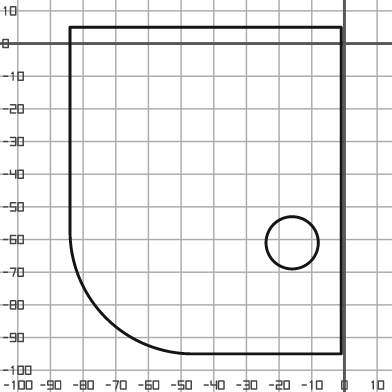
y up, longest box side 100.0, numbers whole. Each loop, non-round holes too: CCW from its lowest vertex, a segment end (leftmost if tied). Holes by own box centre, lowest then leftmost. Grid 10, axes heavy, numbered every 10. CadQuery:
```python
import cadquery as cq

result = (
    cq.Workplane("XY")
    .moveTo(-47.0, -95.0)
    .lineTo(-1.0, -95.0)
    .lineTo(-1.0, 5.0)
    .lineTo(-84.0, 5.0)
    .lineTo(-84.0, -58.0)
    .threePointArc((-73.0, -84.0), (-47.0, -95.0))
    .close()
    .moveTo(-16.0, -61.0)
    .circle(8.0)
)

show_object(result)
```